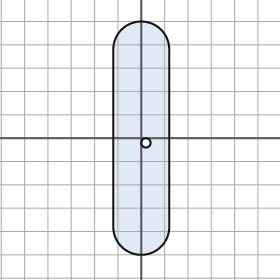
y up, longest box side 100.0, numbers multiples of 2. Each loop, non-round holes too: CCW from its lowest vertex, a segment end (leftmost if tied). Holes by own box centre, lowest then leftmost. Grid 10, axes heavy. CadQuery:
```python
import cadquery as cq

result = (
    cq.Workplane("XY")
    .moveTo(-12.0, -38.0)
    .threePointArc((0.0, -50.0), (12.0, -38.0))
    .lineTo(12.0, 38.0)
    .threePointArc((0.0, 50.0), (-12.0, 38.0))
    .close()
    .moveTo(2.0, -2.0)
    .circle(2.0)
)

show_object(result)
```